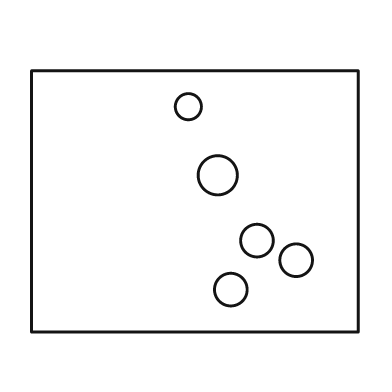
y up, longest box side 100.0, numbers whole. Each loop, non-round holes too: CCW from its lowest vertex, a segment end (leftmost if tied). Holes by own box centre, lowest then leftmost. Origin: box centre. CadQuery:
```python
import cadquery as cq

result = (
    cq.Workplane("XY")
    .moveTo(-50.0, -40.0)
    .lineTo(50.0, -40.0)
    .lineTo(50.0, 40.0)
    .lineTo(-50.0, 40.0)
    .close()
    .moveTo(11.0, -27.0)
    .circle(5.0)
    .moveTo(31.0, -18.0)
    .circle(5.0)
    .moveTo(19.0, -12.0)
    .circle(5.0)
    .moveTo(7.0, 8.0)
    .circle(6.0)
    .moveTo(-2.0, 29.0)
    .circle(4.0)
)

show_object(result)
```